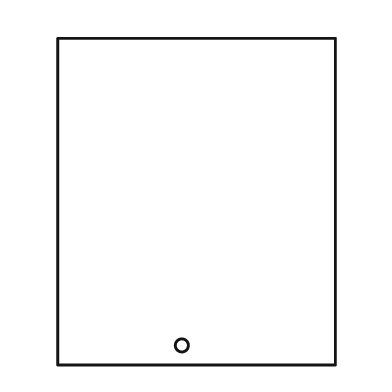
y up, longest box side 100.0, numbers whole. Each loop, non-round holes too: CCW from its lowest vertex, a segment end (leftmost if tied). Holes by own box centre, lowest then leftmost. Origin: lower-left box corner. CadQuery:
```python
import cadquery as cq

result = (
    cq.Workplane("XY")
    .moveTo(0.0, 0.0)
    .lineTo(85.0, 0.0)
    .lineTo(85.0, 100.0)
    .lineTo(0.0, 100.0)
    .close()
    .moveTo(38.0, 6.0)
    .circle(2.0)
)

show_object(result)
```